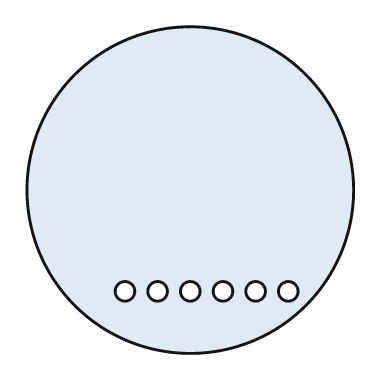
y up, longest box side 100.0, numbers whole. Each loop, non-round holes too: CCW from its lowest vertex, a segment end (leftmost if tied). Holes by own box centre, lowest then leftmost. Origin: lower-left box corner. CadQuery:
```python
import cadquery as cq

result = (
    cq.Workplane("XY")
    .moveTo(50.0, 50.0)
    .circle(50.0)
    .moveTo(30.0, 19.0)
    .circle(3.0)
    .moveTo(40.0, 19.0)
    .circle(3.0)
    .moveTo(50.0, 19.0)
    .circle(3.0)
    .moveTo(60.0, 19.0)
    .circle(3.0)
    .moveTo(70.0, 19.0)
    .circle(3.0)
    .moveTo(80.0, 19.0)
    .circle(3.0)
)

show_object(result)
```